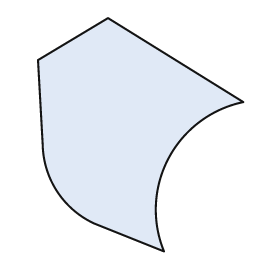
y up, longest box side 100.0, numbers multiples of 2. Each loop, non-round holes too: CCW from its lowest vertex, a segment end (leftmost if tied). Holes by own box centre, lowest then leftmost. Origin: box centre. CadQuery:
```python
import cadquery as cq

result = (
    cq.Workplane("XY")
    .moveTo(10.0, -50.0)
    .threePointArc((12.0, -10.0), (44.0, 14.0))
    .lineTo(-14.0, 50.0)
    .lineTo(-44.0, 32.0)
    .lineTo(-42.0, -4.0)
    .threePointArc((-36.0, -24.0), (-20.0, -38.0))
    .close()
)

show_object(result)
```